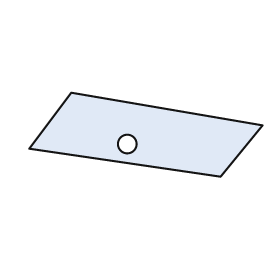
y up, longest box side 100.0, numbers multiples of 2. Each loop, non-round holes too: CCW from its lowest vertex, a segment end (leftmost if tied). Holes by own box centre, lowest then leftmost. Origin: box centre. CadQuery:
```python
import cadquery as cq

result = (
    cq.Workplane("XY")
    .moveTo(32.0, -18.0)
    .lineTo(50.0, 4.0)
    .lineTo(-32.0, 18.0)
    .lineTo(-50.0, -6.0)
    .close()
    .moveTo(-8.0, -4.0)
    .circle(4.0)
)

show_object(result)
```